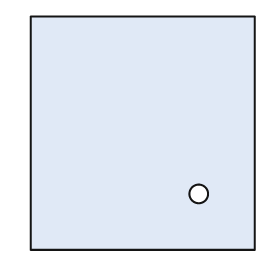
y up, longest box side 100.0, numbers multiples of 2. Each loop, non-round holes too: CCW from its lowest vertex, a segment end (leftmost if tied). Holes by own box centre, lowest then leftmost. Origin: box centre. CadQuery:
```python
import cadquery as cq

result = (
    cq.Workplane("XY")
    .moveTo(-48.0, -50.0)
    .lineTo(48.0, -50.0)
    .lineTo(48.0, 50.0)
    .lineTo(-48.0, 50.0)
    .close()
    .moveTo(24.0, -26.0)
    .circle(4.0)
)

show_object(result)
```